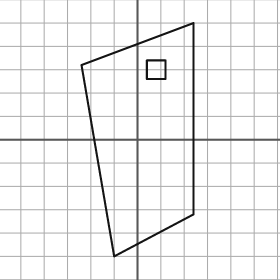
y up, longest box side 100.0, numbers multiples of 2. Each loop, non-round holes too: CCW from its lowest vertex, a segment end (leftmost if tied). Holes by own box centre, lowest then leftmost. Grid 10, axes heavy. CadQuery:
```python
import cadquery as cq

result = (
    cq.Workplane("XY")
    .moveTo(-10.0, -50.0)
    .lineTo(24.0, -32.0)
    .lineTo(24.0, 50.0)
    .lineTo(-24.0, 32.0)
    .close()
    .moveTo(4.0, 26.0)
    .lineTo(12.0, 26.0)
    .lineTo(12.0, 34.0)
    .lineTo(4.0, 34.0)
    .close()
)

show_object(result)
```